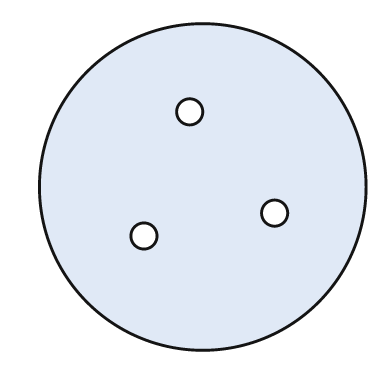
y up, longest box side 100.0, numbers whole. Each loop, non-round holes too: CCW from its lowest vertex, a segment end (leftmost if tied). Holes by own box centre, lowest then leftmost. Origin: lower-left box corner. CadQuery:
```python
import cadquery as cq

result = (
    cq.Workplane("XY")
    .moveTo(50.0, 50.0)
    .circle(50.0)
    .moveTo(32.0, 35.0)
    .circle(4.0)
    .moveTo(72.0, 42.0)
    .circle(4.0)
    .moveTo(46.0, 73.0)
    .circle(4.0)
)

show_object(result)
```